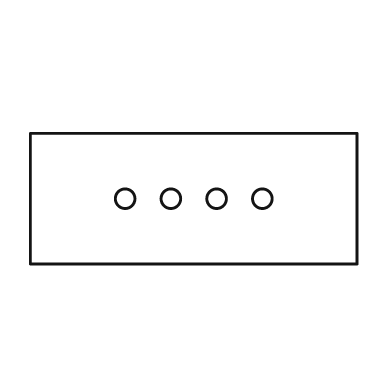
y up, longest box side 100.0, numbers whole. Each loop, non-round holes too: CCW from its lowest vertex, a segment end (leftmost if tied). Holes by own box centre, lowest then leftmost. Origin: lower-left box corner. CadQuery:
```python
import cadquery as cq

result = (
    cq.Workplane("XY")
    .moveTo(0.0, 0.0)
    .lineTo(100.0, 0.0)
    .lineTo(100.0, 40.0)
    .lineTo(0.0, 40.0)
    .close()
    .moveTo(29.0, 20.0)
    .circle(3.0)
    .moveTo(43.0, 20.0)
    .circle(3.0)
    .moveTo(57.0, 20.0)
    .circle(3.0)
    .moveTo(71.0, 20.0)
    .circle(3.0)
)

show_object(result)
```